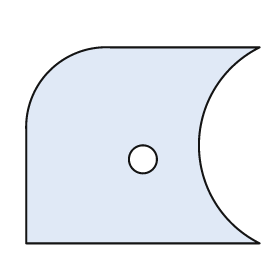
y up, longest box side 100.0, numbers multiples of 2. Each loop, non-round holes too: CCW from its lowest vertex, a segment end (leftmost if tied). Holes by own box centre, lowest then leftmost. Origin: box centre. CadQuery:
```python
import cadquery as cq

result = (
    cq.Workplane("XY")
    .moveTo(-50.0, -42.0)
    .lineTo(50.0, -42.0)
    .threePointArc((24.0, 0.0), (50.0, 42.0))
    .lineTo(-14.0, 42.0)
    .threePointArc((-40.0, 32.0), (-50.0, 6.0))
    .close()
    .moveTo(0.0, -6.0)
    .circle(6.0)
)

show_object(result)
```